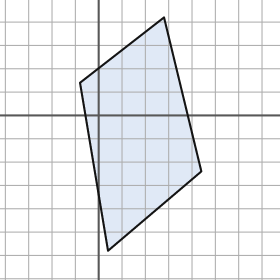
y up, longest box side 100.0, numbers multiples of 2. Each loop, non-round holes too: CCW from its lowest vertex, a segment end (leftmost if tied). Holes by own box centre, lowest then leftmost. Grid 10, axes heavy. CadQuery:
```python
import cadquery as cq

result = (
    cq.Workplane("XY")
    .moveTo(4.0, -58.0)
    .lineTo(44.0, -24.0)
    .lineTo(28.0, 42.0)
    .lineTo(-8.0, 14.0)
    .close()
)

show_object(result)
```